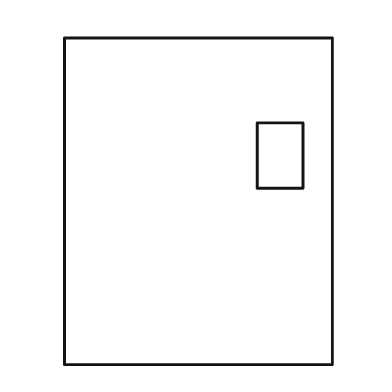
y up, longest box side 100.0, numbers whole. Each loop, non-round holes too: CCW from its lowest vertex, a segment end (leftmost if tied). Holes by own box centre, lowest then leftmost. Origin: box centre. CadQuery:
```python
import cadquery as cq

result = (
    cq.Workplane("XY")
    .moveTo(-41.0, -50.0)
    .lineTo(41.0, -50.0)
    .lineTo(41.0, 50.0)
    .lineTo(-41.0, 50.0)
    .close()
    .moveTo(18.0, 4.0)
    .lineTo(32.0, 4.0)
    .lineTo(32.0, 24.0)
    .lineTo(18.0, 24.0)
    .close()
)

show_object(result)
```